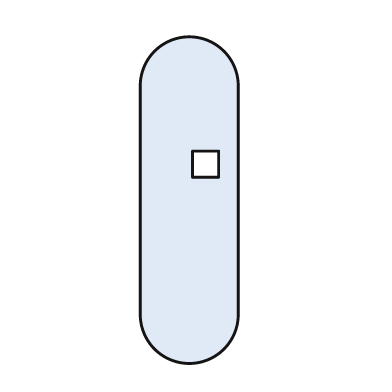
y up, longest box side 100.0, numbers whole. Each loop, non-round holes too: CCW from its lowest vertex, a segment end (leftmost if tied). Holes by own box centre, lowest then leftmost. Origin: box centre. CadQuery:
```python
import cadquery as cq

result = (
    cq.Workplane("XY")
    .moveTo(-15.0, -35.0)
    .threePointArc((0.0, -50.0), (15.0, -35.0))
    .lineTo(15.0, 35.0)
    .threePointArc((0.0, 50.0), (-15.0, 35.0))
    .close()
    .moveTo(1.0, 7.0)
    .lineTo(9.0, 7.0)
    .lineTo(9.0, 15.0)
    .lineTo(1.0, 15.0)
    .close()
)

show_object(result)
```